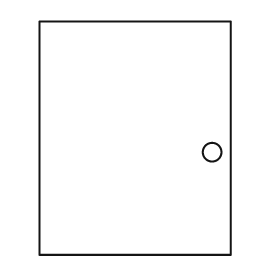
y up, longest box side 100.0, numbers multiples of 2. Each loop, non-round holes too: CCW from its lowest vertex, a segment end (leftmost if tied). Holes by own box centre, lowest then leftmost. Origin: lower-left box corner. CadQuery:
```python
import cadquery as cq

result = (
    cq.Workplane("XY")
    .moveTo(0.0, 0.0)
    .lineTo(82.0, 0.0)
    .lineTo(82.0, 100.0)
    .lineTo(0.0, 100.0)
    .close()
    .moveTo(74.0, 44.0)
    .circle(4.0)
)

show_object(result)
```